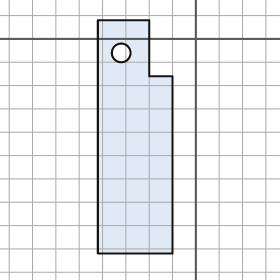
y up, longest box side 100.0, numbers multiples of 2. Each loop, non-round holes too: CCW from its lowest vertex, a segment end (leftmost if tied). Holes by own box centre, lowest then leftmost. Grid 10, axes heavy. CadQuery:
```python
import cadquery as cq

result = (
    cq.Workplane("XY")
    .moveTo(-42.0, -92.0)
    .lineTo(-10.0, -92.0)
    .lineTo(-10.0, -16.0)
    .lineTo(-20.0, -16.0)
    .lineTo(-20.0, 8.0)
    .lineTo(-42.0, 8.0)
    .close()
    .moveTo(-32.0, -6.0)
    .circle(4.0)
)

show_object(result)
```